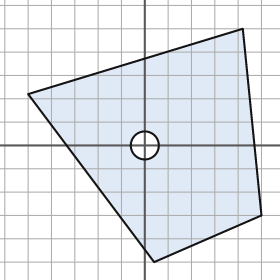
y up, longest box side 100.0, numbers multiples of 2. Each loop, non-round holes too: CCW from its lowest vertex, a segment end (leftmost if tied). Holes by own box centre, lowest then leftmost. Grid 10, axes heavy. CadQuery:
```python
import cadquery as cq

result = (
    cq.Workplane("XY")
    .moveTo(4.0, -50.0)
    .lineTo(50.0, -30.0)
    .lineTo(42.0, 50.0)
    .lineTo(-50.0, 22.0)
    .close()
    .moveTo(0.0, 0.0)
    .circle(6.0)
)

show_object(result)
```